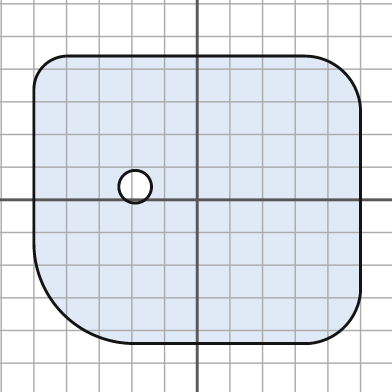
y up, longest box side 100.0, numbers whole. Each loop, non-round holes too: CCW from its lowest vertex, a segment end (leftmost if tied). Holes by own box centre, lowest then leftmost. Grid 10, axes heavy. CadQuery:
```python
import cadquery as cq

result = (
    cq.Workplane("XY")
    .moveTo(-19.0, -44.0)
    .lineTo(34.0, -44.0)
    .threePointArc((45.0, -39.0), (50.0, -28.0))
    .lineTo(50.0, 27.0)
    .threePointArc((45.0, 39.0), (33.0, 44.0))
    .lineTo(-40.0, 44.0)
    .threePointArc((-47.0, 41.0), (-50.0, 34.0))
    .lineTo(-50.0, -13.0)
    .threePointArc((-41.0, -35.0), (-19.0, -44.0))
    .close()
    .moveTo(-19.0, 4.0)
    .circle(5.0)
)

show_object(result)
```